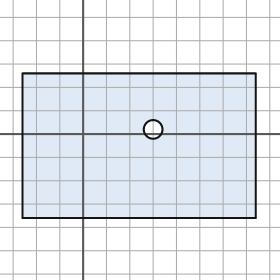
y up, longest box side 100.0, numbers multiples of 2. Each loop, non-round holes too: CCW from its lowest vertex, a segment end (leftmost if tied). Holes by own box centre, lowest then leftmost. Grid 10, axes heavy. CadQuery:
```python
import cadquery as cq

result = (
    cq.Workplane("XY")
    .moveTo(-26.0, -36.0)
    .lineTo(74.0, -36.0)
    .lineTo(74.0, 26.0)
    .lineTo(-26.0, 26.0)
    .close()
    .moveTo(30.0, 2.0)
    .circle(4.0)
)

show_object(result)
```